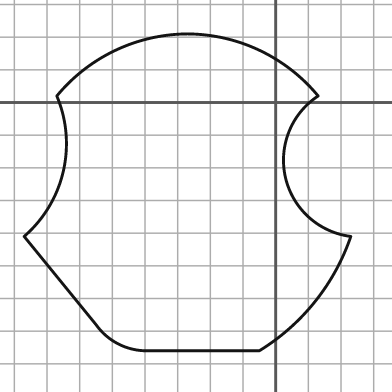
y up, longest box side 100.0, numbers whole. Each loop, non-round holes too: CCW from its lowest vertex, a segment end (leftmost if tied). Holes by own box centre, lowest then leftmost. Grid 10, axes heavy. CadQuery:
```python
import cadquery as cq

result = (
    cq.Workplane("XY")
    .moveTo(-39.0, -76.0)
    .lineTo(-5.0, -76.0)
    .threePointArc((12.0, -61.0), (23.0, -41.0))
    .threePointArc((3.0, -23.0), (13.0, 2.0))
    .threePointArc((-5.0, 16.0), (-27.0, 21.0))
    .threePointArc((-49.0, 16.0), (-67.0, 2.0))
    .threePointArc((-65.0, -21.0), (-77.0, -41.0))
    .lineTo(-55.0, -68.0)
    .threePointArc((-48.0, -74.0), (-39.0, -76.0))
    .close()
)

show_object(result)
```